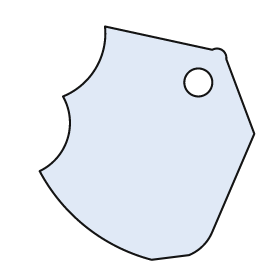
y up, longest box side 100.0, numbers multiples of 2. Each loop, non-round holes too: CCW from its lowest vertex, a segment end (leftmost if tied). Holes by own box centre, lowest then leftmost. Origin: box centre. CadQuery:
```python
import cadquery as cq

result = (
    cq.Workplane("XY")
    .moveTo(2.0, -50.0)
    .lineTo(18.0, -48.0)
    .threePointArc((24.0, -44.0), (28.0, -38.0))
    .lineTo(46.0, 4.0)
    .lineTo(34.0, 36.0)
    .threePointArc((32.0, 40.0), (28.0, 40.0))
    .lineTo(-18.0, 50.0)
    .threePointArc((-22.0, 32.0), (-36.0, 20.0))
    .threePointArc((-34.0, 2.0), (-46.0, -12.0))
    .threePointArc((-26.0, -36.0), (2.0, -50.0))
    .close()
    .moveTo(22.0, 26.0)
    .circle(6.0)
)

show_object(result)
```